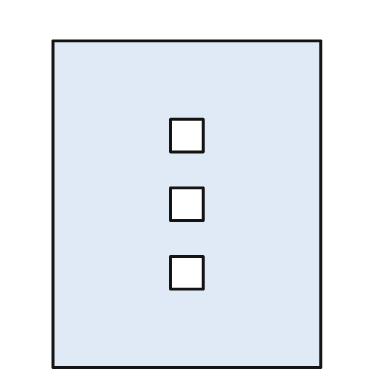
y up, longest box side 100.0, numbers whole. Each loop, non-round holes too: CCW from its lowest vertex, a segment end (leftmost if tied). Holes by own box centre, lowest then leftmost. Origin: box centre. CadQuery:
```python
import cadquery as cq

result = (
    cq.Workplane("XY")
    .moveTo(-41.0, -50.0)
    .lineTo(41.0, -50.0)
    .lineTo(41.0, 50.0)
    .lineTo(-41.0, 50.0)
    .close()
    .moveTo(-5.0, -26.0)
    .lineTo(5.0, -26.0)
    .lineTo(5.0, -16.0)
    .lineTo(-5.0, -16.0)
    .close()
    .moveTo(-5.0, -5.0)
    .lineTo(5.0, -5.0)
    .lineTo(5.0, 5.0)
    .lineTo(-5.0, 5.0)
    .close()
    .moveTo(-5.0, 16.0)
    .lineTo(5.0, 16.0)
    .lineTo(5.0, 26.0)
    .lineTo(-5.0, 26.0)
    .close()
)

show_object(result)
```